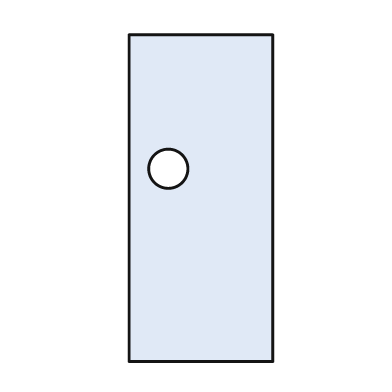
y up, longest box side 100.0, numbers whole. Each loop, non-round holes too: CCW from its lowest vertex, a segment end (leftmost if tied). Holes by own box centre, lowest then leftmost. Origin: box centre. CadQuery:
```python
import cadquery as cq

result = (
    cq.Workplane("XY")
    .moveTo(-22.0, -50.0)
    .lineTo(22.0, -50.0)
    .lineTo(22.0, 50.0)
    .lineTo(-22.0, 50.0)
    .close()
    .moveTo(-10.0, 9.0)
    .circle(6.0)
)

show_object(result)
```